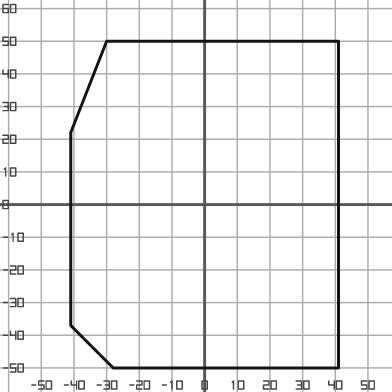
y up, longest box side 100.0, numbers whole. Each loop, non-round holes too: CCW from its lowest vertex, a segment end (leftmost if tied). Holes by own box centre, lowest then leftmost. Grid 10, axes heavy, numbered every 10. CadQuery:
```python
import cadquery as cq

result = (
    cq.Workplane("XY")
    .moveTo(-28.0, -50.0)
    .lineTo(41.0, -50.0)
    .lineTo(41.0, 50.0)
    .lineTo(-30.0, 50.0)
    .lineTo(-41.0, 22.0)
    .lineTo(-41.0, -37.0)
    .close()
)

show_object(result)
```